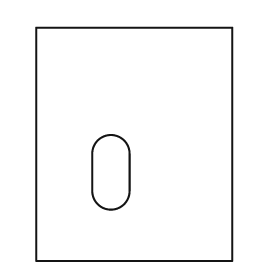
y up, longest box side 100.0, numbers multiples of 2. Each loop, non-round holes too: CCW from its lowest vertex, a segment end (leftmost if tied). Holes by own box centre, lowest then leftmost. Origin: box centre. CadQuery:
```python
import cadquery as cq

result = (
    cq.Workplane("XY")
    .moveTo(-42.0, -50.0)
    .lineTo(42.0, -50.0)
    .lineTo(42.0, 50.0)
    .lineTo(-42.0, 50.0)
    .close()
    .moveTo(-18.0, -20.0)
    .threePointArc((-10.0, -28.0), (-2.0, -20.0))
    .lineTo(-2.0, -4.0)
    .threePointArc((-10.0, 4.0), (-18.0, -4.0))
    .close()
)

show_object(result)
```